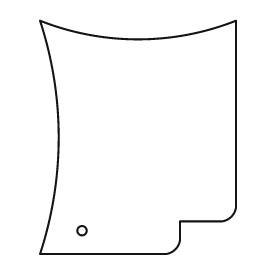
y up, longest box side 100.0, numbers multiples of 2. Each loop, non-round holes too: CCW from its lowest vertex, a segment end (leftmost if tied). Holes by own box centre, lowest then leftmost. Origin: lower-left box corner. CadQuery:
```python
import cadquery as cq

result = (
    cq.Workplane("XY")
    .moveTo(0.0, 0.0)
    .lineTo(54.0, 0.0)
    .threePointArc((58.0, 2.0), (60.0, 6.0))
    .lineTo(60.0, 14.0)
    .lineTo(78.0, 14.0)
    .threePointArc((82.0, 16.0), (84.0, 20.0))
    .lineTo(84.0, 100.0)
    .threePointArc((42.0, 92.0), (0.0, 100.0))
    .threePointArc((8.0, 50.0), (0.0, 0.0))
    .close()
    .moveTo(18.0, 10.0)
    .circle(2.0)
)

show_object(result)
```